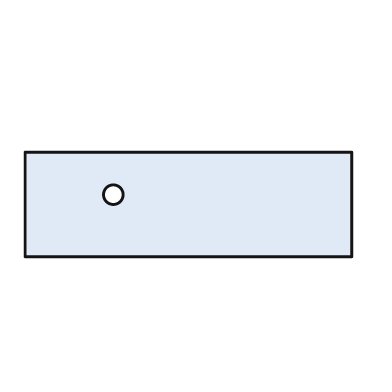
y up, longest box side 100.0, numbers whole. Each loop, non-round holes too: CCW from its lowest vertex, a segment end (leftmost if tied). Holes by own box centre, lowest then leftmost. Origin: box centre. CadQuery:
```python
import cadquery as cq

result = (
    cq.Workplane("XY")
    .moveTo(-50.0, -16.0)
    .lineTo(50.0, -16.0)
    .lineTo(50.0, 16.0)
    .lineTo(-50.0, 16.0)
    .close()
    .moveTo(-23.0, 3.0)
    .circle(3.0)
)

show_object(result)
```